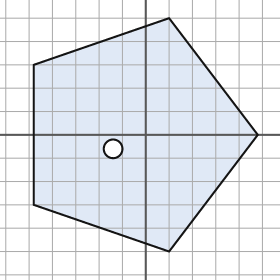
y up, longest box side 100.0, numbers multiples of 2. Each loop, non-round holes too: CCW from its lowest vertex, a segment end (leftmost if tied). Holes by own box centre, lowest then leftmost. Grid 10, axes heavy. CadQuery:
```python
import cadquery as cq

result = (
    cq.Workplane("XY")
    .moveTo(10.0, -50.0)
    .lineTo(48.0, 0.0)
    .lineTo(10.0, 50.0)
    .lineTo(-48.0, 30.0)
    .lineTo(-48.0, -30.0)
    .close()
    .moveTo(-14.0, -6.0)
    .circle(4.0)
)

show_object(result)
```